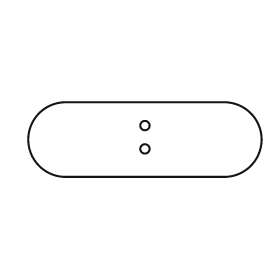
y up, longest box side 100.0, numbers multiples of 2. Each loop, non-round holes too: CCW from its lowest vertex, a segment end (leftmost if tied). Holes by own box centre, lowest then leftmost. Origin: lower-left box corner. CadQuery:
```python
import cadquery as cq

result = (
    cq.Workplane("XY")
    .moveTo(16.0, 0.0)
    .lineTo(84.0, 0.0)
    .threePointArc((100.0, 16.0), (84.0, 32.0))
    .lineTo(16.0, 32.0)
    .threePointArc((0.0, 16.0), (16.0, 0.0))
    .close()
    .moveTo(50.0, 12.0)
    .circle(2.0)
    .moveTo(50.0, 22.0)
    .circle(2.0)
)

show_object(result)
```